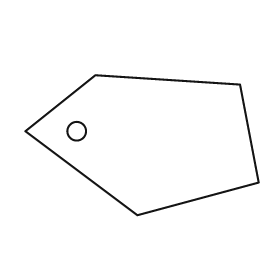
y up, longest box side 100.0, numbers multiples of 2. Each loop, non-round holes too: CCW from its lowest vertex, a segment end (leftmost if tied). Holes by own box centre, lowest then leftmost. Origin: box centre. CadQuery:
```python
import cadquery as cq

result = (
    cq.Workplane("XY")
    .moveTo(-2.0, -30.0)
    .lineTo(50.0, -16.0)
    .lineTo(42.0, 26.0)
    .lineTo(-20.0, 30.0)
    .lineTo(-50.0, 6.0)
    .close()
    .moveTo(-28.0, 6.0)
    .circle(4.0)
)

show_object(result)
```